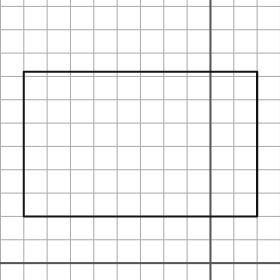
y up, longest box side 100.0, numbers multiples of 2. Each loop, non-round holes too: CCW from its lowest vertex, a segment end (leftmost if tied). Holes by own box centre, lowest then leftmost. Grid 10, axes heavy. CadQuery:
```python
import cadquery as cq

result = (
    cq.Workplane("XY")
    .moveTo(-80.0, 20.0)
    .lineTo(20.0, 20.0)
    .lineTo(20.0, 82.0)
    .lineTo(-80.0, 82.0)
    .close()
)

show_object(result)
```